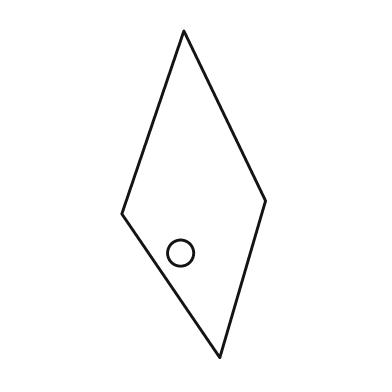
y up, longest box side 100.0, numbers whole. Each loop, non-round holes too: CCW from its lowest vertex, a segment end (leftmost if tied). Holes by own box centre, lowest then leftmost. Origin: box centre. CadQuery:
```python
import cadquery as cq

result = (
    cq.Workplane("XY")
    .moveTo(8.0, -50.0)
    .lineTo(22.0, -2.0)
    .lineTo(-3.0, 50.0)
    .lineTo(-22.0, -6.0)
    .close()
    .moveTo(-4.0, -18.0)
    .circle(4.0)
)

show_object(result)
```